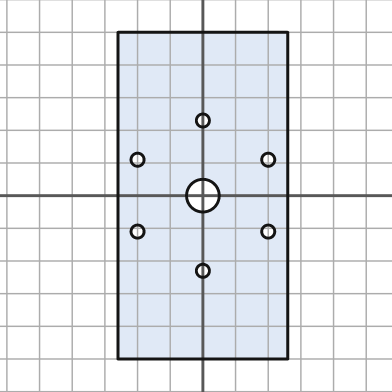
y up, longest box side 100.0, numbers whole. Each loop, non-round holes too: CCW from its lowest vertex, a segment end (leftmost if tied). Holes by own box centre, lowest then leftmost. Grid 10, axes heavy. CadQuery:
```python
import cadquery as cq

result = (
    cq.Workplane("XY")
    .moveTo(-26.0, -50.0)
    .lineTo(26.0, -50.0)
    .lineTo(26.0, 50.0)
    .lineTo(-26.0, 50.0)
    .close()
    .moveTo(0.0, -23.0)
    .circle(2.0)
    .moveTo(-20.0, -11.0)
    .circle(2.0)
    .moveTo(20.0, -11.0)
    .circle(2.0)
    .moveTo(0.0, 0.0)
    .circle(5.0)
    .moveTo(-20.0, 11.0)
    .circle(2.0)
    .moveTo(20.0, 11.0)
    .circle(2.0)
    .moveTo(0.0, 23.0)
    .circle(2.0)
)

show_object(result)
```